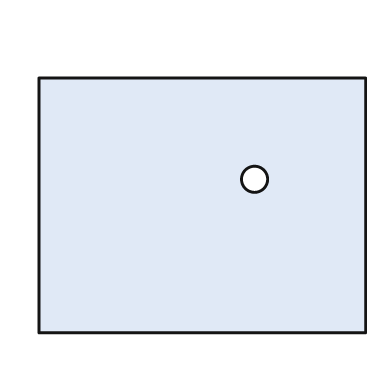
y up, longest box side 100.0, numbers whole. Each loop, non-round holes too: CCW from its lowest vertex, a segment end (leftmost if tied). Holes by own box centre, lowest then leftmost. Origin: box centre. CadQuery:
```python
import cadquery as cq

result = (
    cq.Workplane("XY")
    .moveTo(-50.0, -39.0)
    .lineTo(50.0, -39.0)
    .lineTo(50.0, 39.0)
    .lineTo(-50.0, 39.0)
    .close()
    .moveTo(16.0, 8.0)
    .circle(4.0)
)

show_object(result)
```